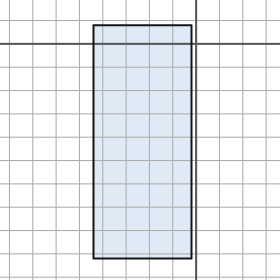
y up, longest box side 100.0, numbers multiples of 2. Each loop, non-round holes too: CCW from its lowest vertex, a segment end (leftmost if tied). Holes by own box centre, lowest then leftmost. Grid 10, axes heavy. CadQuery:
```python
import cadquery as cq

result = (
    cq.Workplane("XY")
    .moveTo(-44.0, -92.0)
    .lineTo(-2.0, -92.0)
    .lineTo(-2.0, 8.0)
    .lineTo(-44.0, 8.0)
    .close()
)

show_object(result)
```